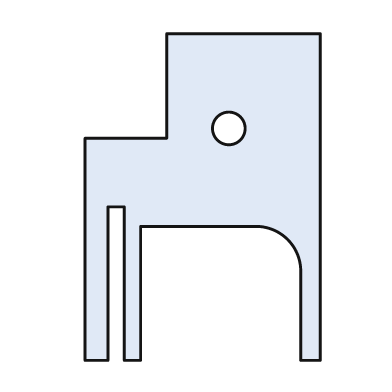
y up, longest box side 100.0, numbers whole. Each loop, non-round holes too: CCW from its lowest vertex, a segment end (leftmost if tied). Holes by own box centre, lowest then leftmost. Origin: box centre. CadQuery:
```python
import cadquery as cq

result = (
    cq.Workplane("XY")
    .moveTo(-36.0, -50.0)
    .lineTo(-29.0, -50.0)
    .lineTo(-29.0, -3.0)
    .lineTo(-24.0, -3.0)
    .lineTo(-24.0, -50.0)
    .lineTo(-19.0, -50.0)
    .lineTo(-19.0, -9.0)
    .lineTo(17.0, -9.0)
    .threePointArc((26.0, -13.0), (30.0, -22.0))
    .lineTo(30.0, -50.0)
    .lineTo(36.0, -50.0)
    .lineTo(36.0, 50.0)
    .lineTo(-11.0, 50.0)
    .lineTo(-11.0, 18.0)
    .lineTo(-36.0, 18.0)
    .close()
    .moveTo(8.0, 21.0)
    .circle(5.0)
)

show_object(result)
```